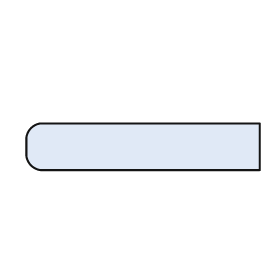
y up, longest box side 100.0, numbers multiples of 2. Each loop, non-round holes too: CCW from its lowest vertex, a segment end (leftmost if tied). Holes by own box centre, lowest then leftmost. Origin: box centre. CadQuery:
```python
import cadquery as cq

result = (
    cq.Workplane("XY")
    .moveTo(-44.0, -10.0)
    .lineTo(50.0, -10.0)
    .lineTo(50.0, 10.0)
    .lineTo(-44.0, 10.0)
    .threePointArc((-48.0, 8.0), (-50.0, 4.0))
    .lineTo(-50.0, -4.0)
    .threePointArc((-48.0, -8.0), (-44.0, -10.0))
    .close()
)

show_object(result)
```